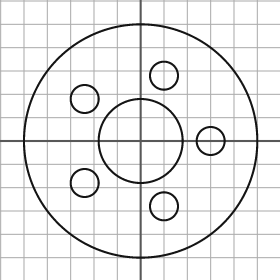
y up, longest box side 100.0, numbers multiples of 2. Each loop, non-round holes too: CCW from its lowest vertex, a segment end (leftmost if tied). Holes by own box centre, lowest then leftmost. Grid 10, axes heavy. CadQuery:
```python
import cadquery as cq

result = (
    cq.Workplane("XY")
    .moveTo(0.0, 0.0)
    .circle(50.0)
    .moveTo(10.0, -28.0)
    .circle(6.0)
    .moveTo(-24.0, -18.0)
    .circle(6.0)
    .moveTo(0.0, 0.0)
    .circle(18.0)
    .moveTo(30.0, 0.0)
    .circle(6.0)
    .moveTo(-24.0, 18.0)
    .circle(6.0)
    .moveTo(10.0, 28.0)
    .circle(6.0)
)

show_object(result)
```